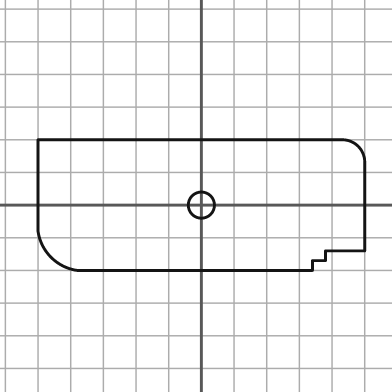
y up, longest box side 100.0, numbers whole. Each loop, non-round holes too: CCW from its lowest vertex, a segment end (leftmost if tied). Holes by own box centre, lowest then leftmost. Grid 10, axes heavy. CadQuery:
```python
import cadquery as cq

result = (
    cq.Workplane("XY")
    .moveTo(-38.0, -20.0)
    .lineTo(34.0, -20.0)
    .lineTo(34.0, -17.0)
    .lineTo(38.0, -17.0)
    .lineTo(38.0, -14.0)
    .lineTo(50.0, -14.0)
    .lineTo(50.0, 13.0)
    .threePointArc((48.0, 18.0), (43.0, 20.0))
    .lineTo(-50.0, 20.0)
    .lineTo(-50.0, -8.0)
    .threePointArc((-46.0, -16.0), (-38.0, -20.0))
    .close()
    .moveTo(0.0, 0.0)
    .circle(4.0)
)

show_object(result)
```